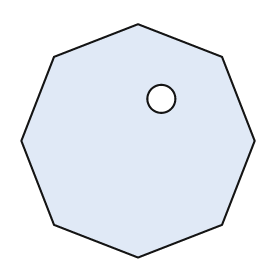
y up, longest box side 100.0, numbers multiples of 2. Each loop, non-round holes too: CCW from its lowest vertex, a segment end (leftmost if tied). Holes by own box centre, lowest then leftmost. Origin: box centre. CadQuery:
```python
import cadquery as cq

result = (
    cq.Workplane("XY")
    .moveTo(0.0, -50.0)
    .lineTo(36.0, -36.0)
    .lineTo(50.0, 0.0)
    .lineTo(36.0, 36.0)
    .lineTo(0.0, 50.0)
    .lineTo(-36.0, 36.0)
    .lineTo(-50.0, 0.0)
    .lineTo(-36.0, -36.0)
    .close()
    .moveTo(10.0, 18.0)
    .circle(6.0)
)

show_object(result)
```